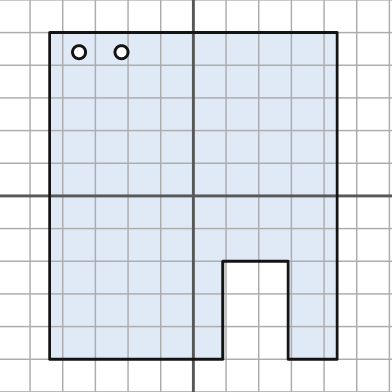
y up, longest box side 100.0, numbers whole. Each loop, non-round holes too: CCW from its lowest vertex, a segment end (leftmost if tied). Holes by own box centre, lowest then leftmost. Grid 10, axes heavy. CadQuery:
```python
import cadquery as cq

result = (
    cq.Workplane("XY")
    .moveTo(-44.0, -50.0)
    .lineTo(9.0, -50.0)
    .lineTo(9.0, -20.0)
    .lineTo(29.0, -20.0)
    .lineTo(29.0, -50.0)
    .lineTo(44.0, -50.0)
    .lineTo(44.0, 50.0)
    .lineTo(-44.0, 50.0)
    .close()
    .moveTo(-35.0, 44.0)
    .circle(2.0)
    .moveTo(-22.0, 44.0)
    .circle(2.0)
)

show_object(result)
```